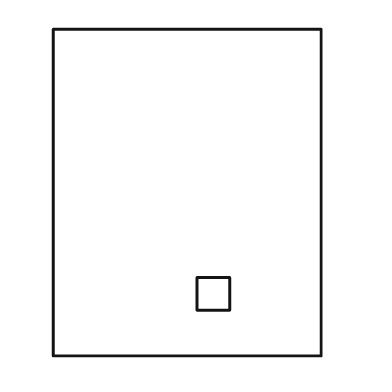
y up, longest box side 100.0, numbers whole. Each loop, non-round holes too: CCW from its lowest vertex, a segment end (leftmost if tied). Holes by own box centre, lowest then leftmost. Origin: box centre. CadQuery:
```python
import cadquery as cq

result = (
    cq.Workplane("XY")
    .moveTo(-41.0, -50.0)
    .lineTo(41.0, -50.0)
    .lineTo(41.0, 50.0)
    .lineTo(-41.0, 50.0)
    .close()
    .moveTo(3.0, -36.0)
    .lineTo(13.0, -36.0)
    .lineTo(13.0, -26.0)
    .lineTo(3.0, -26.0)
    .close()
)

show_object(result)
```